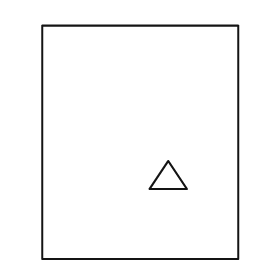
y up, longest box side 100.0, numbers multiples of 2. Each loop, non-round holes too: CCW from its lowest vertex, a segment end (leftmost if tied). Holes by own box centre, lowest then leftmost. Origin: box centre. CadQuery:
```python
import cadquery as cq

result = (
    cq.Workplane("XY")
    .moveTo(-42.0, -50.0)
    .lineTo(42.0, -50.0)
    .lineTo(42.0, 50.0)
    .lineTo(-42.0, 50.0)
    .close()
    .moveTo(4.0, -20.0)
    .lineTo(20.0, -20.0)
    .lineTo(12.0, -8.0)
    .close()
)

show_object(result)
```